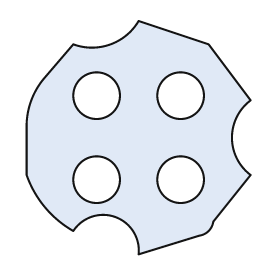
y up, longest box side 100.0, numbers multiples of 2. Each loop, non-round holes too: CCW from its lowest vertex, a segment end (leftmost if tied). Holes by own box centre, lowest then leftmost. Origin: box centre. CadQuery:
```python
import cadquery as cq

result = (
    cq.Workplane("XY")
    .moveTo(0.0, -50.0)
    .lineTo(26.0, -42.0)
    .threePointArc((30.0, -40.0), (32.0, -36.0))
    .lineTo(48.0, -16.0)
    .threePointArc((40.0, 0.0), (48.0, 16.0))
    .lineTo(30.0, 40.0)
    .lineTo(0.0, 50.0)
    .threePointArc((-12.0, 40.0), (-28.0, 40.0))
    .lineTo(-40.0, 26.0)
    .threePointArc((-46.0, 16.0), (-48.0, 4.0))
    .lineTo(-48.0, -16.0)
    .threePointArc((-40.0, -30.0), (-28.0, -40.0))
    .threePointArc((-10.0, -34.0), (0.0, -50.0))
    .close()
    .moveTo(-18.0, -18.0)
    .circle(10.0)
    .moveTo(18.0, -18.0)
    .circle(10.0)
    .moveTo(-18.0, 18.0)
    .circle(10.0)
    .moveTo(18.0, 18.0)
    .circle(10.0)
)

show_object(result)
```